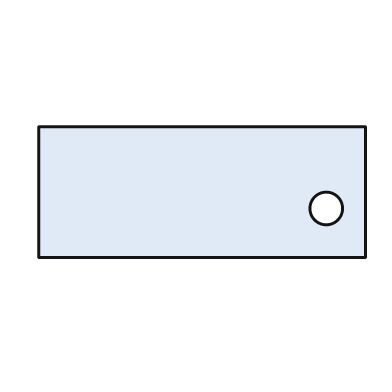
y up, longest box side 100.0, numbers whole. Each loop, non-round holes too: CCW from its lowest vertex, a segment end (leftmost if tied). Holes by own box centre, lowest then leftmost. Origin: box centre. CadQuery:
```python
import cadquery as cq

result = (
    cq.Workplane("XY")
    .moveTo(-50.0, -20.0)
    .lineTo(50.0, -20.0)
    .lineTo(50.0, 20.0)
    .lineTo(-50.0, 20.0)
    .close()
    .moveTo(38.0, -5.0)
    .circle(5.0)
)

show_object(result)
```